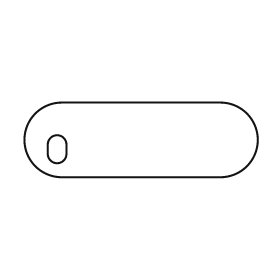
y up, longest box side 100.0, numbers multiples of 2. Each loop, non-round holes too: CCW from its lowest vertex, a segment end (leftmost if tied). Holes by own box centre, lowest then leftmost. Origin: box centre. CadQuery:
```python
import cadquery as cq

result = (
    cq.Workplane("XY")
    .moveTo(-34.0, -16.0)
    .lineTo(34.0, -16.0)
    .threePointArc((50.0, 0.0), (34.0, 16.0))
    .lineTo(-34.0, 16.0)
    .threePointArc((-50.0, 0.0), (-34.0, -16.0))
    .close()
    .moveTo(-40.0, -6.0)
    .threePointArc((-36.0, -10.0), (-32.0, -6.0))
    .lineTo(-32.0, -2.0)
    .threePointArc((-36.0, 2.0), (-40.0, -2.0))
    .close()
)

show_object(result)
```